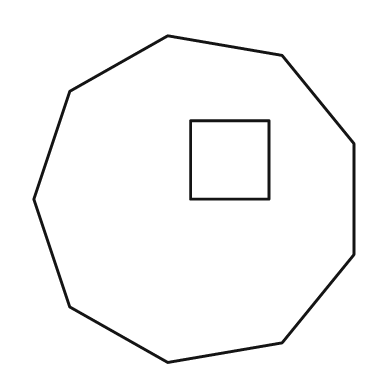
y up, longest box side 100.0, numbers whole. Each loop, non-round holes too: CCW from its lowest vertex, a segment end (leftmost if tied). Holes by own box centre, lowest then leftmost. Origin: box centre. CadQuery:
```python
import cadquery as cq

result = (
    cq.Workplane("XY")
    .moveTo(-8.0, -50.0)
    .lineTo(27.0, -44.0)
    .lineTo(49.0, -17.0)
    .lineTo(49.0, 17.0)
    .lineTo(27.0, 44.0)
    .lineTo(-8.0, 50.0)
    .lineTo(-38.0, 33.0)
    .lineTo(-49.0, 0.0)
    .lineTo(-38.0, -33.0)
    .close()
    .moveTo(-1.0, 0.0)
    .lineTo(23.0, 0.0)
    .lineTo(23.0, 24.0)
    .lineTo(-1.0, 24.0)
    .close()
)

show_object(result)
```